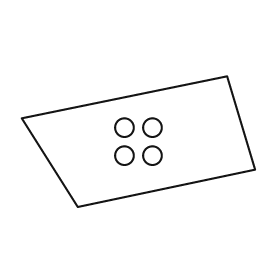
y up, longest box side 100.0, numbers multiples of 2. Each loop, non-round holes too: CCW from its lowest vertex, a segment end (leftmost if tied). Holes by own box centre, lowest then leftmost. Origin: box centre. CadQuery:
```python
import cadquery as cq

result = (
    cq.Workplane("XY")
    .moveTo(-26.0, -28.0)
    .lineTo(50.0, -12.0)
    .lineTo(38.0, 28.0)
    .lineTo(-50.0, 10.0)
    .close()
    .moveTo(-6.0, -6.0)
    .circle(4.0)
    .moveTo(6.0, -6.0)
    .circle(4.0)
    .moveTo(-6.0, 6.0)
    .circle(4.0)
    .moveTo(6.0, 6.0)
    .circle(4.0)
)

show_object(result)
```